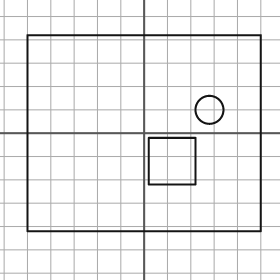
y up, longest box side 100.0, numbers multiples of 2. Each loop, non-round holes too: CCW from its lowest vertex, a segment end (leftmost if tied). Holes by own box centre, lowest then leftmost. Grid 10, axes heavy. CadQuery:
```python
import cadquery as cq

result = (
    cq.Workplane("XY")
    .moveTo(-50.0, -42.0)
    .lineTo(50.0, -42.0)
    .lineTo(50.0, 42.0)
    .lineTo(-50.0, 42.0)
    .close()
    .moveTo(2.0, -22.0)
    .lineTo(22.0, -22.0)
    .lineTo(22.0, -2.0)
    .lineTo(2.0, -2.0)
    .close()
    .moveTo(28.0, 10.0)
    .circle(6.0)
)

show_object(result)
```